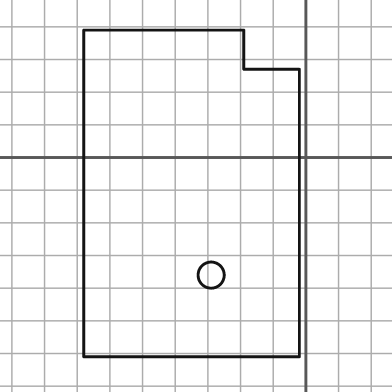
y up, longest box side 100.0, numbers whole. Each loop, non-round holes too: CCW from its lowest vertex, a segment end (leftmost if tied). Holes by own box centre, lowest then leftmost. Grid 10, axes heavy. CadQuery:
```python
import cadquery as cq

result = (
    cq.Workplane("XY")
    .moveTo(-68.0, -61.0)
    .lineTo(-2.0, -61.0)
    .lineTo(-2.0, 27.0)
    .lineTo(-19.0, 27.0)
    .lineTo(-19.0, 39.0)
    .lineTo(-68.0, 39.0)
    .close()
    .moveTo(-29.0, -36.0)
    .circle(4.0)
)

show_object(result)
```